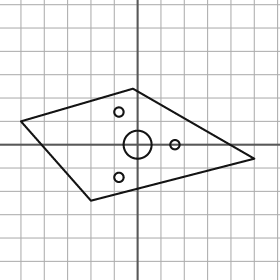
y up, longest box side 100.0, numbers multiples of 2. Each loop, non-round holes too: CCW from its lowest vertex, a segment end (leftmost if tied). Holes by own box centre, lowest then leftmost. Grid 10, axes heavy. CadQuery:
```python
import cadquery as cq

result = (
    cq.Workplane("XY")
    .moveTo(-20.0, -24.0)
    .lineTo(50.0, -6.0)
    .lineTo(-2.0, 24.0)
    .lineTo(-50.0, 10.0)
    .close()
    .moveTo(-8.0, -14.0)
    .circle(2.0)
    .moveTo(0.0, 0.0)
    .circle(6.0)
    .moveTo(16.0, 0.0)
    .circle(2.0)
    .moveTo(-8.0, 14.0)
    .circle(2.0)
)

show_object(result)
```